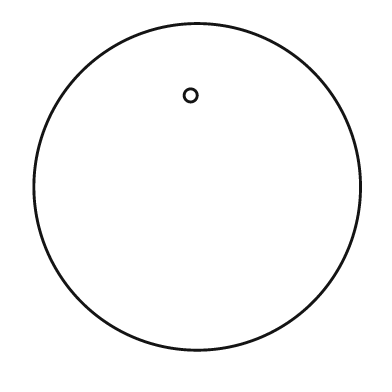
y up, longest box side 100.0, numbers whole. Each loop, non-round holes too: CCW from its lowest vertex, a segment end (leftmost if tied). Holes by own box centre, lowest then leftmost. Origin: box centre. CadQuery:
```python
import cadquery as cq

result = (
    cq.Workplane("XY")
    .moveTo(0.0, 0.0)
    .circle(50.0)
    .moveTo(-2.0, 28.0)
    .circle(2.0)
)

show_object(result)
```